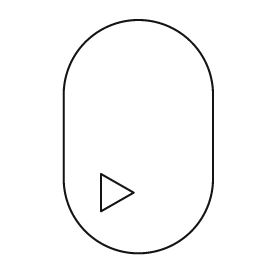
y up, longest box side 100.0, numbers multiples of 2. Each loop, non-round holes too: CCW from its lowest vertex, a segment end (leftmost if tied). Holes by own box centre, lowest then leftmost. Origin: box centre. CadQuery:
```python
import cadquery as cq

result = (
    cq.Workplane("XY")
    .moveTo(-32.0, -18.0)
    .threePointArc((0.0, -50.0), (32.0, -18.0))
    .lineTo(32.0, 18.0)
    .threePointArc((0.0, 50.0), (-32.0, 18.0))
    .close()
    .moveTo(-16.0, -32.0)
    .lineTo(-2.0, -24.0)
    .lineTo(-16.0, -16.0)
    .close()
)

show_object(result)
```